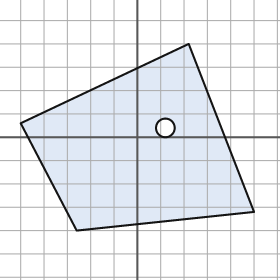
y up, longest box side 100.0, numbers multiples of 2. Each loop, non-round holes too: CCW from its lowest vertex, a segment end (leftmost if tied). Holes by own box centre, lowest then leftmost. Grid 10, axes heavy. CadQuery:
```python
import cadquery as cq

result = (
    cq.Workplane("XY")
    .moveTo(-26.0, -40.0)
    .lineTo(50.0, -32.0)
    .lineTo(22.0, 40.0)
    .lineTo(-50.0, 6.0)
    .close()
    .moveTo(12.0, 4.0)
    .circle(4.0)
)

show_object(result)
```